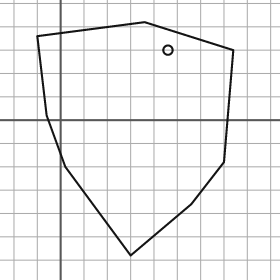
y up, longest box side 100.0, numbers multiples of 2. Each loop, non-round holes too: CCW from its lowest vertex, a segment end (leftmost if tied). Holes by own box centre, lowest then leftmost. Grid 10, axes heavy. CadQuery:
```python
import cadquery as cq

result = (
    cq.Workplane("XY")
    .moveTo(30.0, -58.0)
    .lineTo(56.0, -36.0)
    .lineTo(70.0, -18.0)
    .lineTo(74.0, 30.0)
    .lineTo(36.0, 42.0)
    .lineTo(-10.0, 36.0)
    .lineTo(-6.0, 2.0)
    .lineTo(2.0, -20.0)
    .close()
    .moveTo(46.0, 30.0)
    .circle(2.0)
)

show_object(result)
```